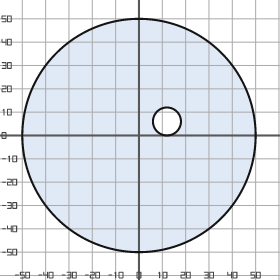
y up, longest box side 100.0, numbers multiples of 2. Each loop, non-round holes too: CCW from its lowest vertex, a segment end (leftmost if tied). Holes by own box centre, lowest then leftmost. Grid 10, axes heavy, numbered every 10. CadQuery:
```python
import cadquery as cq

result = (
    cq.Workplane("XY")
    .moveTo(0.0, 0.0)
    .circle(50.0)
    .moveTo(12.0, 6.0)
    .circle(6.0)
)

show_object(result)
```